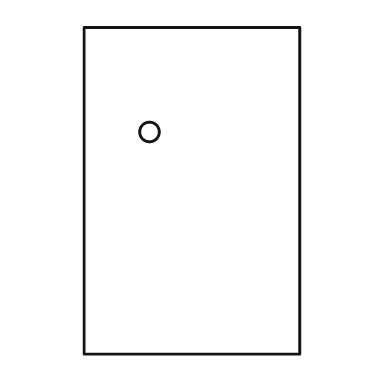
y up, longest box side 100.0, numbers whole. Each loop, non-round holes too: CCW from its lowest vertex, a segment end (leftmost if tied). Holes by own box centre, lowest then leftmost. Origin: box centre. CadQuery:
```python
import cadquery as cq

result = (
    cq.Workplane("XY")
    .moveTo(-33.0, -50.0)
    .lineTo(33.0, -50.0)
    .lineTo(33.0, 50.0)
    .lineTo(-33.0, 50.0)
    .close()
    .moveTo(-13.0, 18.0)
    .circle(3.0)
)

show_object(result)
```